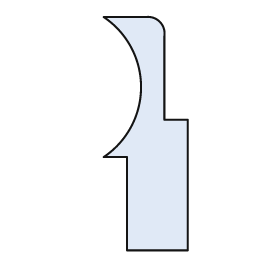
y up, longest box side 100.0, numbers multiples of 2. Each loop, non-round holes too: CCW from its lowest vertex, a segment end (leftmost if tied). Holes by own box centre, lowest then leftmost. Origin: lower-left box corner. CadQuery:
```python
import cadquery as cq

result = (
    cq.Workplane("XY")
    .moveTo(10.0, 0.0)
    .lineTo(36.0, 0.0)
    .lineTo(36.0, 56.0)
    .lineTo(26.0, 56.0)
    .lineTo(26.0, 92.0)
    .threePointArc((24.0, 98.0), (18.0, 100.0))
    .lineTo(0.0, 100.0)
    .threePointArc((16.0, 70.0), (0.0, 40.0))
    .lineTo(10.0, 40.0)
    .close()
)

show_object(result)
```